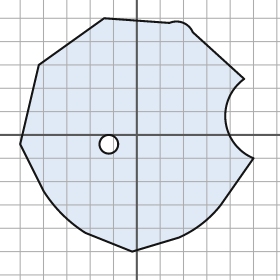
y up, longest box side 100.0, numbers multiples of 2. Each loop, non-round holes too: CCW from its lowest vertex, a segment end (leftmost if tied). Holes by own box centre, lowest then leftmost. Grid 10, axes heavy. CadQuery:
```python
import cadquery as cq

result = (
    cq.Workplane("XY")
    .moveTo(-2.0, -50.0)
    .lineTo(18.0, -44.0)
    .threePointArc((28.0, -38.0), (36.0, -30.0))
    .lineTo(50.0, -10.0)
    .threePointArc((38.0, 6.0), (46.0, 24.0))
    .lineTo(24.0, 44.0)
    .threePointArc((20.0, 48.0), (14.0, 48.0))
    .lineTo(-14.0, 50.0)
    .lineTo(-42.0, 30.0)
    .lineTo(-50.0, -4.0)
    .lineTo(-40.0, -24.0)
    .threePointArc((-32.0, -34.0), (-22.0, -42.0))
    .close()
    .moveTo(-12.0, -4.0)
    .circle(4.0)
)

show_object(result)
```